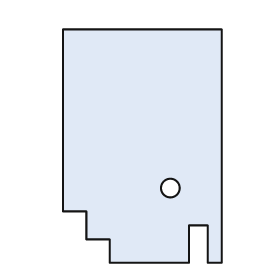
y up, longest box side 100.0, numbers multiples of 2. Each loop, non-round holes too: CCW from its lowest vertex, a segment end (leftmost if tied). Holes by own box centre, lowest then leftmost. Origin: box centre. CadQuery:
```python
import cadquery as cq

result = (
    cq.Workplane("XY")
    .moveTo(-14.0, -50.0)
    .lineTo(20.0, -50.0)
    .lineTo(20.0, -34.0)
    .lineTo(28.0, -34.0)
    .lineTo(28.0, -50.0)
    .lineTo(34.0, -50.0)
    .lineTo(34.0, 50.0)
    .lineTo(-34.0, 50.0)
    .lineTo(-34.0, -28.0)
    .lineTo(-24.0, -28.0)
    .lineTo(-24.0, -40.0)
    .lineTo(-14.0, -40.0)
    .close()
    .moveTo(12.0, -18.0)
    .circle(4.0)
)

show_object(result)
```